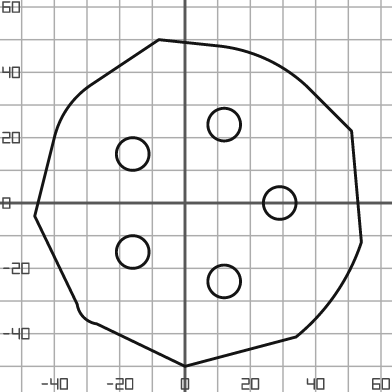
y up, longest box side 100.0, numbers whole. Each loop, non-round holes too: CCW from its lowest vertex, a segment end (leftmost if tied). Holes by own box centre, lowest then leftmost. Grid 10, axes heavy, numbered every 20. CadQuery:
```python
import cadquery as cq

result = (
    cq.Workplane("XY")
    .moveTo(0.0, -50.0)
    .lineTo(34.0, -41.0)
    .threePointArc((46.0, -28.0), (54.0, -12.0))
    .lineTo(51.0, 22.0)
    .lineTo(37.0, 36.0)
    .threePointArc((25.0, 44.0), (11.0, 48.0))
    .lineTo(-8.0, 50.0)
    .lineTo(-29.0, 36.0)
    .threePointArc((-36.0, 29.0), (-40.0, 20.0))
    .lineTo(-46.0, -4.0)
    .lineTo(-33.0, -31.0)
    .threePointArc((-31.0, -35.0), (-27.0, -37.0))
    .close()
    .moveTo(12.0, -24.0)
    .circle(5.0)
    .moveTo(-16.0, -15.0)
    .circle(5.0)
    .moveTo(29.0, 0.0)
    .circle(5.0)
    .moveTo(-16.0, 15.0)
    .circle(5.0)
    .moveTo(12.0, 24.0)
    .circle(5.0)
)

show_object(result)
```